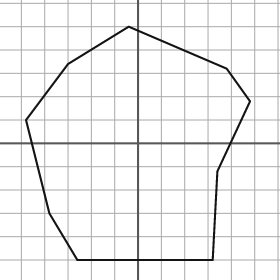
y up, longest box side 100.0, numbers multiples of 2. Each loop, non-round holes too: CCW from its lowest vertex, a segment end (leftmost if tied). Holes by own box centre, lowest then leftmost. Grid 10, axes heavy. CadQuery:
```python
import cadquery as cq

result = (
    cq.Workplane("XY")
    .moveTo(-26.0, -50.0)
    .lineTo(32.0, -50.0)
    .lineTo(34.0, -12.0)
    .lineTo(48.0, 18.0)
    .lineTo(38.0, 32.0)
    .lineTo(-4.0, 50.0)
    .lineTo(-30.0, 34.0)
    .lineTo(-48.0, 10.0)
    .lineTo(-38.0, -30.0)
    .close()
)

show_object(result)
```